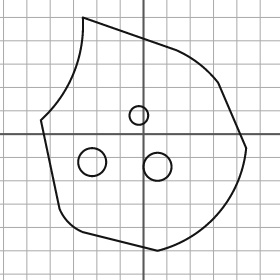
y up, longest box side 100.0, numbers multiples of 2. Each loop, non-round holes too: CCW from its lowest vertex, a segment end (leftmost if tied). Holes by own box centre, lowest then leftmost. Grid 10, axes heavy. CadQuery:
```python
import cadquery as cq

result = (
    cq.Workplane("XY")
    .moveTo(6.0, -50.0)
    .threePointArc((32.0, -34.0), (44.0, -6.0))
    .lineTo(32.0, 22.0)
    .threePointArc((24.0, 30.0), (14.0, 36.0))
    .lineTo(-26.0, 50.0)
    .threePointArc((-30.0, 26.0), (-44.0, 6.0))
    .lineTo(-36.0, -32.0)
    .threePointArc((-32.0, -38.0), (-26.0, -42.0))
    .close()
    .moveTo(6.0, -14.0)
    .circle(6.0)
    .moveTo(-22.0, -12.0)
    .circle(6.0)
    .moveTo(-2.0, 8.0)
    .circle(4.0)
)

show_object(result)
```